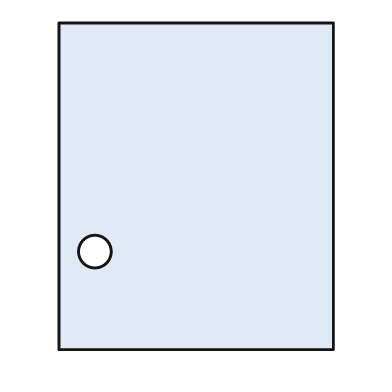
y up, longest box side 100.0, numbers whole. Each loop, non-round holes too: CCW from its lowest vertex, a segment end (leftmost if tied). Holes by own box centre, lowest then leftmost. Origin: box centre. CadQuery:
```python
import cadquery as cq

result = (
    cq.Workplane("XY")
    .moveTo(-42.0, -50.0)
    .lineTo(42.0, -50.0)
    .lineTo(42.0, 50.0)
    .lineTo(-42.0, 50.0)
    .close()
    .moveTo(-31.0, -20.0)
    .circle(5.0)
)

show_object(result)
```